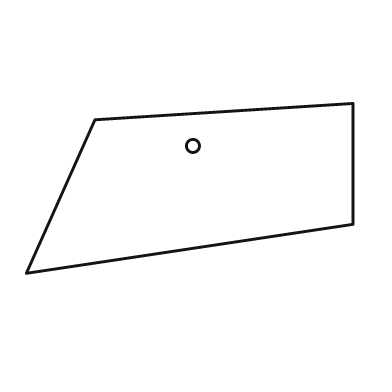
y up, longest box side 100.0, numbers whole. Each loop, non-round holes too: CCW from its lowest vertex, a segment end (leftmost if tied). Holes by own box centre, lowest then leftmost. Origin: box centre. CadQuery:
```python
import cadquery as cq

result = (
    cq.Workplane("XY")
    .moveTo(-50.0, -26.0)
    .lineTo(50.0, -11.0)
    .lineTo(50.0, 26.0)
    .lineTo(-29.0, 21.0)
    .close()
    .moveTo(1.0, 13.0)
    .circle(2.0)
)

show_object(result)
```